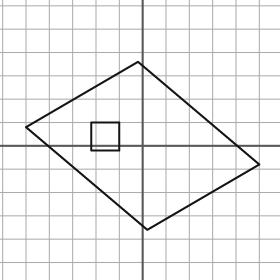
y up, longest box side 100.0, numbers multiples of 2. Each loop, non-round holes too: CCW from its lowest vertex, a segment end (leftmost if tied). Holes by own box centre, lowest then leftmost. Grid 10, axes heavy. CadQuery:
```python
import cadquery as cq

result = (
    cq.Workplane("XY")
    .moveTo(2.0, -36.0)
    .lineTo(50.0, -8.0)
    .lineTo(-2.0, 36.0)
    .lineTo(-50.0, 8.0)
    .close()
    .moveTo(-22.0, -2.0)
    .lineTo(-10.0, -2.0)
    .lineTo(-10.0, 10.0)
    .lineTo(-22.0, 10.0)
    .close()
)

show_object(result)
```